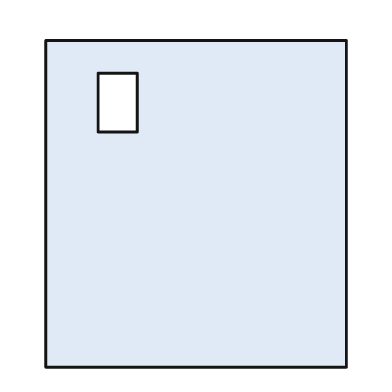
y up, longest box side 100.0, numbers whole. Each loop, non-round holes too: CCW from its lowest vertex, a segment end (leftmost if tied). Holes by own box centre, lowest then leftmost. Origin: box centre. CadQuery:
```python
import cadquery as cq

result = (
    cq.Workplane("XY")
    .moveTo(-46.0, -50.0)
    .lineTo(46.0, -50.0)
    .lineTo(46.0, 50.0)
    .lineTo(-46.0, 50.0)
    .close()
    .moveTo(-30.0, 22.0)
    .lineTo(-18.0, 22.0)
    .lineTo(-18.0, 40.0)
    .lineTo(-30.0, 40.0)
    .close()
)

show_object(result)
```